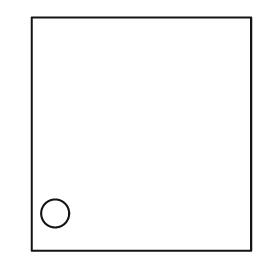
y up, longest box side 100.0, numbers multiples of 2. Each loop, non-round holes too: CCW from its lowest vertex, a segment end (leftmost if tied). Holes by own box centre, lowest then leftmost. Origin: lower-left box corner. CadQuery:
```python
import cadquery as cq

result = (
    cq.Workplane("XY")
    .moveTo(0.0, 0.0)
    .lineTo(94.0, 0.0)
    .lineTo(94.0, 100.0)
    .lineTo(0.0, 100.0)
    .close()
    .moveTo(10.0, 16.0)
    .circle(6.0)
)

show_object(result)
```